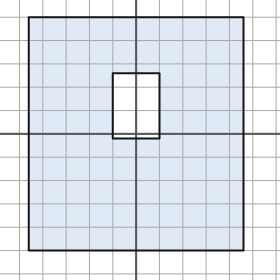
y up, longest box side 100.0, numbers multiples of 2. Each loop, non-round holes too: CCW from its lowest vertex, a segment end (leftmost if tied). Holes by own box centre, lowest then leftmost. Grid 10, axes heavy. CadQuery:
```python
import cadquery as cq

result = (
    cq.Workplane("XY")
    .moveTo(-46.0, -50.0)
    .lineTo(46.0, -50.0)
    .lineTo(46.0, 50.0)
    .lineTo(-46.0, 50.0)
    .close()
    .moveTo(-10.0, -2.0)
    .lineTo(10.0, -2.0)
    .lineTo(10.0, 26.0)
    .lineTo(-10.0, 26.0)
    .close()
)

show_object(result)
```